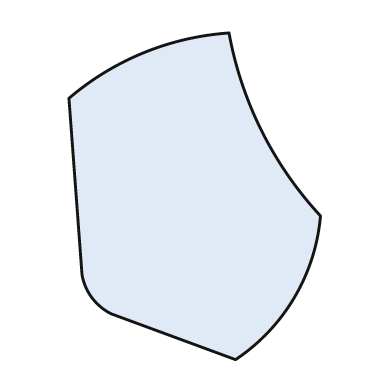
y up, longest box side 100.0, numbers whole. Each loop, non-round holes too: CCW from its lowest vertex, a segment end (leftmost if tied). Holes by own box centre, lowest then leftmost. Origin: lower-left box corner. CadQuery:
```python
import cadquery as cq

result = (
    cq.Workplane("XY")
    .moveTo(51.0, 0.0)
    .threePointArc((69.0, 19.0), (77.0, 44.0))
    .threePointArc((59.0, 70.0), (49.0, 100.0))
    .threePointArc((23.0, 94.0), (0.0, 80.0))
    .lineTo(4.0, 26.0)
    .threePointArc((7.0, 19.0), (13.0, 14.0))
    .close()
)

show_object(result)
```